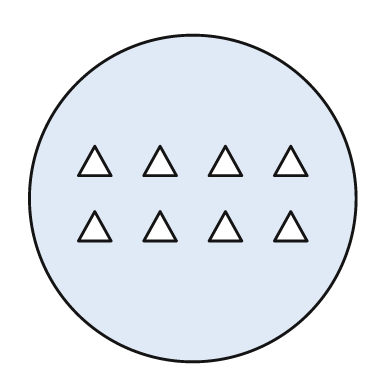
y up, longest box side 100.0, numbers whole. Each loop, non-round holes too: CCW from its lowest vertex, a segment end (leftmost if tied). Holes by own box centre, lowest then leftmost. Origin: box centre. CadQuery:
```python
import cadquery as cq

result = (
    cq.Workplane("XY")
    .moveTo(0.0, 0.0)
    .circle(50.0)
    .moveTo(-35.0, -13.0)
    .lineTo(-25.0, -13.0)
    .lineTo(-30.0, -4.0)
    .close()
    .moveTo(-15.0, -13.0)
    .lineTo(-5.0, -13.0)
    .lineTo(-10.0, -4.0)
    .close()
    .moveTo(5.0, -13.0)
    .lineTo(15.0, -13.0)
    .lineTo(10.0, -4.0)
    .close()
    .moveTo(25.0, -13.0)
    .lineTo(35.0, -13.0)
    .lineTo(30.0, -4.0)
    .close()
    .moveTo(-35.0, 7.0)
    .lineTo(-25.0, 7.0)
    .lineTo(-30.0, 16.0)
    .close()
    .moveTo(-15.0, 7.0)
    .lineTo(-5.0, 7.0)
    .lineTo(-10.0, 16.0)
    .close()
    .moveTo(5.0, 7.0)
    .lineTo(15.0, 7.0)
    .lineTo(10.0, 16.0)
    .close()
    .moveTo(25.0, 7.0)
    .lineTo(35.0, 7.0)
    .lineTo(30.0, 16.0)
    .close()
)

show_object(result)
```